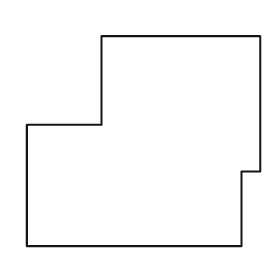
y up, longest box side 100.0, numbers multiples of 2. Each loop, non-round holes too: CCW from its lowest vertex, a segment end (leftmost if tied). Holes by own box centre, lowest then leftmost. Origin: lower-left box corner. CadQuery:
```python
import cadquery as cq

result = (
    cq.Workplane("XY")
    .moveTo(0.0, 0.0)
    .lineTo(92.0, 0.0)
    .lineTo(92.0, 32.0)
    .lineTo(100.0, 32.0)
    .lineTo(100.0, 90.0)
    .lineTo(32.0, 90.0)
    .lineTo(32.0, 52.0)
    .lineTo(0.0, 52.0)
    .close()
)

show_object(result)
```